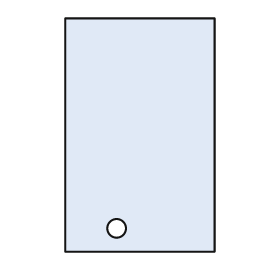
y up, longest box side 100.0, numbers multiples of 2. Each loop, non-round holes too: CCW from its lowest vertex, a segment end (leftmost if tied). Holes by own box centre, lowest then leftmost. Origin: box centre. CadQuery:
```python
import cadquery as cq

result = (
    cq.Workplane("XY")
    .moveTo(-32.0, -50.0)
    .lineTo(32.0, -50.0)
    .lineTo(32.0, 50.0)
    .lineTo(-32.0, 50.0)
    .close()
    .moveTo(-10.0, -40.0)
    .circle(4.0)
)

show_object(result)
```